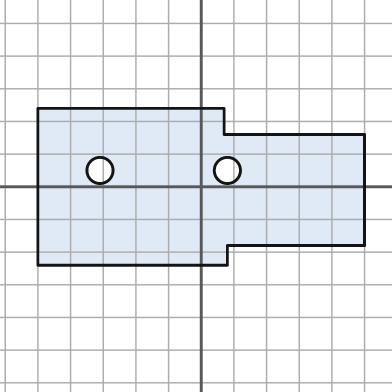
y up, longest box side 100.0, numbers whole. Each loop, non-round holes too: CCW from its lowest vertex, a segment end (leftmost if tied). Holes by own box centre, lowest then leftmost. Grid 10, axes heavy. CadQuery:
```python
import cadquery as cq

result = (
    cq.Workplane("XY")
    .moveTo(-50.0, -24.0)
    .lineTo(8.0, -24.0)
    .lineTo(8.0, -18.0)
    .lineTo(50.0, -18.0)
    .lineTo(50.0, 16.0)
    .lineTo(7.0, 16.0)
    .lineTo(7.0, 24.0)
    .lineTo(-50.0, 24.0)
    .close()
    .moveTo(-31.0, 5.0)
    .circle(4.0)
    .moveTo(8.0, 5.0)
    .circle(4.0)
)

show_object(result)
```